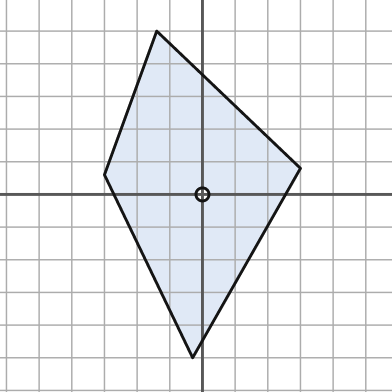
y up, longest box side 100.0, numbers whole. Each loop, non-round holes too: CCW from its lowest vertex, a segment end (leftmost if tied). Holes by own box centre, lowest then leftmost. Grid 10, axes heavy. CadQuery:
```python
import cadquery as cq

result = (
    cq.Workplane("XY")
    .moveTo(-3.0, -50.0)
    .lineTo(30.0, 8.0)
    .lineTo(-14.0, 50.0)
    .lineTo(-30.0, 6.0)
    .close()
    .moveTo(0.0, 0.0)
    .circle(2.0)
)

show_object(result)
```